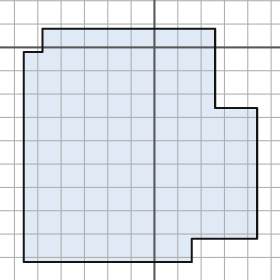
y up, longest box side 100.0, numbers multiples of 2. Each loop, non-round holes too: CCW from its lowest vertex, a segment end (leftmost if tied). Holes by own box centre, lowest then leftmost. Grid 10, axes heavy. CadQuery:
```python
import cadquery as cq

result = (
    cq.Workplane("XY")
    .moveTo(-56.0, -92.0)
    .lineTo(16.0, -92.0)
    .lineTo(16.0, -82.0)
    .lineTo(44.0, -82.0)
    .lineTo(44.0, -26.0)
    .lineTo(26.0, -26.0)
    .lineTo(26.0, 8.0)
    .lineTo(-48.0, 8.0)
    .lineTo(-48.0, -2.0)
    .lineTo(-56.0, -2.0)
    .close()
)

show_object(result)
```